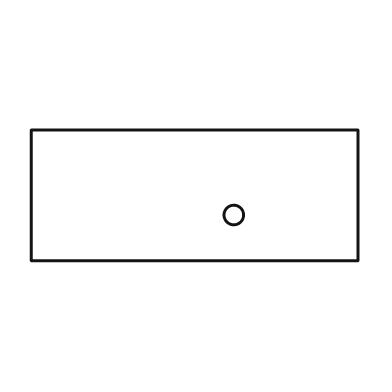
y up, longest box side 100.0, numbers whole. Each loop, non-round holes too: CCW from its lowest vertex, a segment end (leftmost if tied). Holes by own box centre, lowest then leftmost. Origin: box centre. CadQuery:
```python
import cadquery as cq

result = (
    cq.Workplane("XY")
    .moveTo(-50.0, -20.0)
    .lineTo(50.0, -20.0)
    .lineTo(50.0, 20.0)
    .lineTo(-50.0, 20.0)
    .close()
    .moveTo(12.0, -6.0)
    .circle(3.0)
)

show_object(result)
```